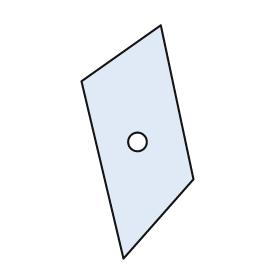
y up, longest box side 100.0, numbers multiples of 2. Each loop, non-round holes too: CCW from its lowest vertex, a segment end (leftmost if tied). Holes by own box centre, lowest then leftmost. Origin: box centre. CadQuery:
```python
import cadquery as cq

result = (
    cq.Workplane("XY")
    .moveTo(-6.0, -50.0)
    .lineTo(24.0, -16.0)
    .lineTo(10.0, 50.0)
    .lineTo(-24.0, 26.0)
    .close()
    .moveTo(0.0, 0.0)
    .circle(4.0)
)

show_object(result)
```